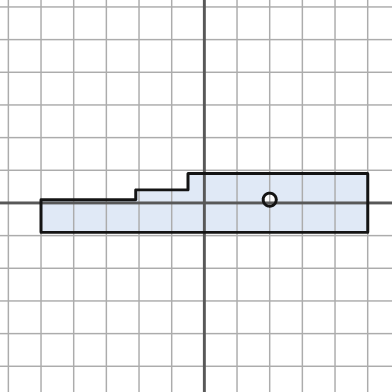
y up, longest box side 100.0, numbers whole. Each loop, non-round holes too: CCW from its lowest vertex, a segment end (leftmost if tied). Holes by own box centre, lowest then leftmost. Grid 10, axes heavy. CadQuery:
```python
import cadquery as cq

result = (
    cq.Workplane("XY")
    .moveTo(-50.0, -9.0)
    .lineTo(50.0, -9.0)
    .lineTo(50.0, 9.0)
    .lineTo(-5.0, 9.0)
    .lineTo(-5.0, 4.0)
    .lineTo(-21.0, 4.0)
    .lineTo(-21.0, 1.0)
    .lineTo(-50.0, 1.0)
    .close()
    .moveTo(20.0, 1.0)
    .circle(2.0)
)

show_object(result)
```